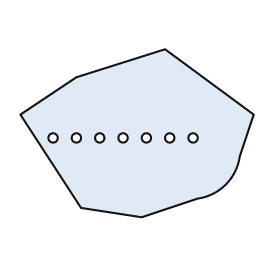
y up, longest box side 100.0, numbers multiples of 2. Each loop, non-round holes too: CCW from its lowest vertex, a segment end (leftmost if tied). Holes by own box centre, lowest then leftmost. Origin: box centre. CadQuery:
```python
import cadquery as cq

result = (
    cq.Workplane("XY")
    .moveTo(2.0, -36.0)
    .lineTo(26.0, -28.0)
    .threePointArc((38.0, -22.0), (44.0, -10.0))
    .lineTo(50.0, 8.0)
    .lineTo(12.0, 36.0)
    .lineTo(-26.0, 24.0)
    .lineTo(-50.0, 8.0)
    .lineTo(-24.0, -32.0)
    .close()
    .moveTo(-36.0, -2.0)
    .circle(2.0)
    .moveTo(-26.0, -2.0)
    .circle(2.0)
    .moveTo(-16.0, -2.0)
    .circle(2.0)
    .moveTo(-6.0, -2.0)
    .circle(2.0)
    .moveTo(4.0, -2.0)
    .circle(2.0)
    .moveTo(14.0, -2.0)
    .circle(2.0)
    .moveTo(24.0, -2.0)
    .circle(2.0)
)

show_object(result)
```